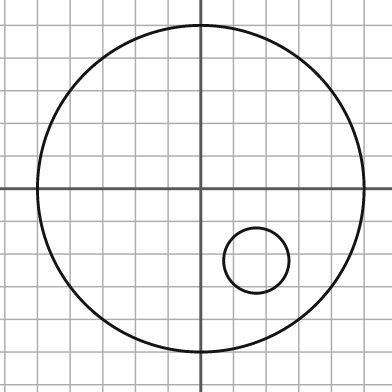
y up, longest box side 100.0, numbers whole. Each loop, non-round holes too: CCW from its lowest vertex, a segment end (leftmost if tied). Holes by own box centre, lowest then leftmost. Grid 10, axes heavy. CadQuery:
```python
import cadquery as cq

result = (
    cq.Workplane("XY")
    .moveTo(0.0, 0.0)
    .circle(50.0)
    .moveTo(17.0, -22.0)
    .circle(10.0)
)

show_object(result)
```